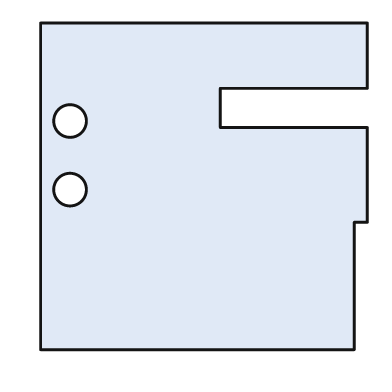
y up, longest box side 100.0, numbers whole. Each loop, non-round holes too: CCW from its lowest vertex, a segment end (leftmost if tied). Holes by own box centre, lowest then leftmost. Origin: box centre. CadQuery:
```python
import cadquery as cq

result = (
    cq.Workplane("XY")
    .moveTo(-50.0, -50.0)
    .lineTo(46.0, -50.0)
    .lineTo(46.0, -11.0)
    .lineTo(50.0, -11.0)
    .lineTo(50.0, 18.0)
    .lineTo(5.0, 18.0)
    .lineTo(5.0, 30.0)
    .lineTo(50.0, 30.0)
    .lineTo(50.0, 50.0)
    .lineTo(-50.0, 50.0)
    .close()
    .moveTo(-41.0, -1.0)
    .circle(5.0)
    .moveTo(-41.0, 20.0)
    .circle(5.0)
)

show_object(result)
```